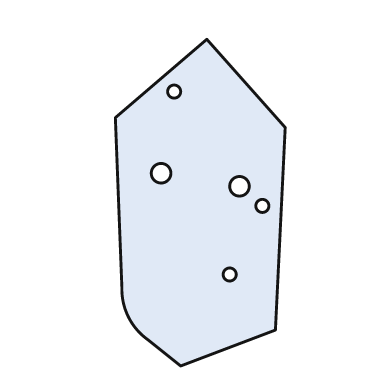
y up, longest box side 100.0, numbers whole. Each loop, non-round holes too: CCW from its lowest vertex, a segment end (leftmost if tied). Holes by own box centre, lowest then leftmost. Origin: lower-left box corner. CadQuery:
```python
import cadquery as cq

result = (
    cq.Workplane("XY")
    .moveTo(20.0, 0.0)
    .lineTo(49.0, 11.0)
    .lineTo(52.0, 73.0)
    .lineTo(28.0, 100.0)
    .lineTo(0.0, 76.0)
    .lineTo(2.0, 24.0)
    .threePointArc((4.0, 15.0), (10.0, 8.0))
    .close()
    .moveTo(35.0, 28.0)
    .circle(2.0)
    .moveTo(45.0, 49.0)
    .circle(2.0)
    .moveTo(38.0, 55.0)
    .circle(3.0)
    .moveTo(14.0, 59.0)
    .circle(3.0)
    .moveTo(18.0, 84.0)
    .circle(2.0)
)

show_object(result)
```